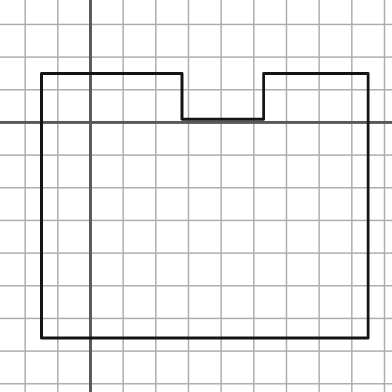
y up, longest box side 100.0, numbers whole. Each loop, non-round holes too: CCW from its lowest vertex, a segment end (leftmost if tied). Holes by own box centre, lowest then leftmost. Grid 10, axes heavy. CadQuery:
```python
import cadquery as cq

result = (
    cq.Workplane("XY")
    .moveTo(-15.0, -66.0)
    .lineTo(85.0, -66.0)
    .lineTo(85.0, 15.0)
    .lineTo(53.0, 15.0)
    .lineTo(53.0, 1.0)
    .lineTo(28.0, 1.0)
    .lineTo(28.0, 15.0)
    .lineTo(-15.0, 15.0)
    .close()
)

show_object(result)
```